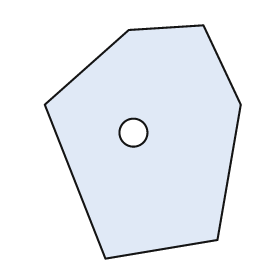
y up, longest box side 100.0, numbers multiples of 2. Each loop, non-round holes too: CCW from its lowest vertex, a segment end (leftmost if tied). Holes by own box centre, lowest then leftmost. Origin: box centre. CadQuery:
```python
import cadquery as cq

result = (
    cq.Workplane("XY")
    .moveTo(-16.0, -50.0)
    .lineTo(32.0, -42.0)
    .lineTo(42.0, 16.0)
    .lineTo(26.0, 50.0)
    .lineTo(-6.0, 48.0)
    .lineTo(-42.0, 16.0)
    .close()
    .moveTo(-4.0, 4.0)
    .circle(6.0)
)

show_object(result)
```